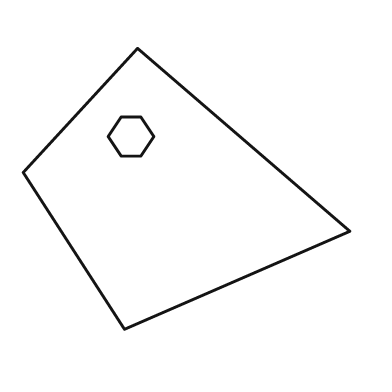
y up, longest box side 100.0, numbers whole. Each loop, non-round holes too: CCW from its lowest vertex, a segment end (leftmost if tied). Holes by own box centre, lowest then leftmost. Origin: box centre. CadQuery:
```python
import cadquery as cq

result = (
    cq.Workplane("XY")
    .moveTo(-19.0, -43.0)
    .lineTo(50.0, -13.0)
    .lineTo(-15.0, 43.0)
    .lineTo(-50.0, 5.0)
    .close()
    .moveTo(-20.0, 10.0)
    .lineTo(-14.0, 10.0)
    .lineTo(-10.0, 16.0)
    .lineTo(-14.0, 22.0)
    .lineTo(-20.0, 22.0)
    .lineTo(-24.0, 16.0)
    .close()
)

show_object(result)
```